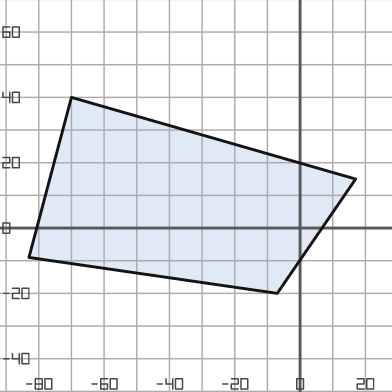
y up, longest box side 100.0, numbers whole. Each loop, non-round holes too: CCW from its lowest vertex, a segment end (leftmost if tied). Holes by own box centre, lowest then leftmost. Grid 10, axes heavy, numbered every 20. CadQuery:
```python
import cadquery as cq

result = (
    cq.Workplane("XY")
    .moveTo(-7.0, -20.0)
    .lineTo(17.0, 15.0)
    .lineTo(-70.0, 40.0)
    .lineTo(-83.0, -9.0)
    .close()
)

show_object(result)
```